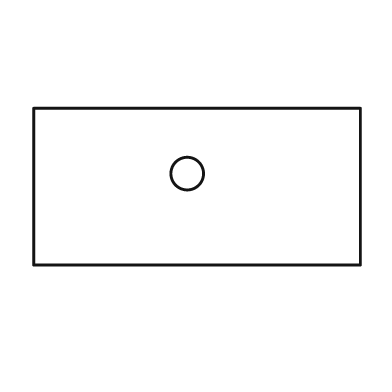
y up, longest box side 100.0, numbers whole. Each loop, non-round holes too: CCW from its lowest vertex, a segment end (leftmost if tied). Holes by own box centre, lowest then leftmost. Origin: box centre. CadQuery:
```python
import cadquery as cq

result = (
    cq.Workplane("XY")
    .moveTo(-50.0, -24.0)
    .lineTo(50.0, -24.0)
    .lineTo(50.0, 24.0)
    .lineTo(-50.0, 24.0)
    .close()
    .moveTo(-3.0, 4.0)
    .circle(5.0)
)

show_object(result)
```